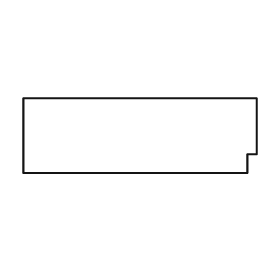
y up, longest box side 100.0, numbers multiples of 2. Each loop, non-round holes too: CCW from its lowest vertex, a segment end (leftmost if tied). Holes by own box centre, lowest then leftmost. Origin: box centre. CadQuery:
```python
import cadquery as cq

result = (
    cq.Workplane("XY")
    .moveTo(-50.0, -16.0)
    .lineTo(46.0, -16.0)
    .lineTo(46.0, -8.0)
    .lineTo(50.0, -8.0)
    .lineTo(50.0, 16.0)
    .lineTo(-50.0, 16.0)
    .close()
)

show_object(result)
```